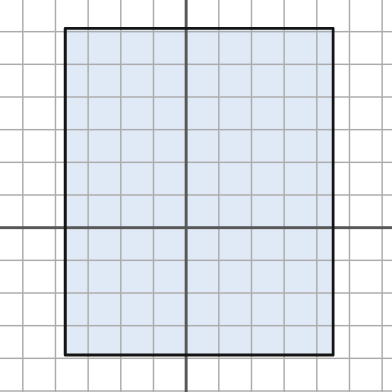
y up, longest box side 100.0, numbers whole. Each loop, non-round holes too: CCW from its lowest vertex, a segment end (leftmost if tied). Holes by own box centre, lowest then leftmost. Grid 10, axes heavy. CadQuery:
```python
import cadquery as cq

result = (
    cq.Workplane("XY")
    .moveTo(-37.0, -39.0)
    .lineTo(45.0, -39.0)
    .lineTo(45.0, 61.0)
    .lineTo(-37.0, 61.0)
    .close()
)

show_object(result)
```